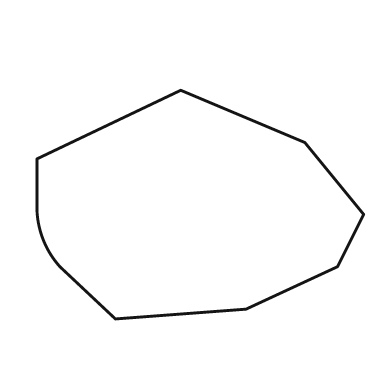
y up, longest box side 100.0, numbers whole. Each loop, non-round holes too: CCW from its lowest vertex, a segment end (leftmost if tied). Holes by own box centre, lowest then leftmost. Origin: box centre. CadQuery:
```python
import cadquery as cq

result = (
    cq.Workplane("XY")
    .moveTo(-26.0, -35.0)
    .lineTo(14.0, -32.0)
    .lineTo(42.0, -19.0)
    .lineTo(50.0, -3.0)
    .lineTo(32.0, 19.0)
    .lineTo(-6.0, 35.0)
    .lineTo(-50.0, 14.0)
    .lineTo(-50.0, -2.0)
    .threePointArc((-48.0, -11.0), (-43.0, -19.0))
    .close()
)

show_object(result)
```